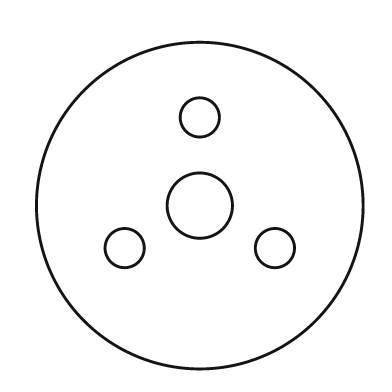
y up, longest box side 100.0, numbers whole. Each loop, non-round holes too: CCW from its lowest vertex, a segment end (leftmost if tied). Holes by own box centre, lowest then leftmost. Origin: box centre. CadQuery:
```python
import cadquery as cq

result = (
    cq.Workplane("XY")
    .moveTo(0.0, 0.0)
    .circle(50.0)
    .moveTo(-23.0, -13.0)
    .circle(6.0)
    .moveTo(23.0, -13.0)
    .circle(6.0)
    .moveTo(0.0, 0.0)
    .circle(10.0)
    .moveTo(0.0, 27.0)
    .circle(6.0)
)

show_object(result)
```